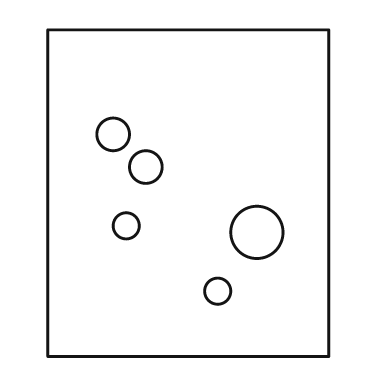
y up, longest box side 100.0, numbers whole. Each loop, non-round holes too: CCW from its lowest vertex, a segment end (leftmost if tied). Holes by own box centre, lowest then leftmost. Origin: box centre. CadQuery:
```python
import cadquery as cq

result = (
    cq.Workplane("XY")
    .moveTo(-43.0, -50.0)
    .lineTo(43.0, -50.0)
    .lineTo(43.0, 50.0)
    .lineTo(-43.0, 50.0)
    .close()
    .moveTo(9.0, -30.0)
    .circle(4.0)
    .moveTo(21.0, -12.0)
    .circle(8.0)
    .moveTo(-19.0, -10.0)
    .circle(4.0)
    .moveTo(-13.0, 8.0)
    .circle(5.0)
    .moveTo(-23.0, 18.0)
    .circle(5.0)
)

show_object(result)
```